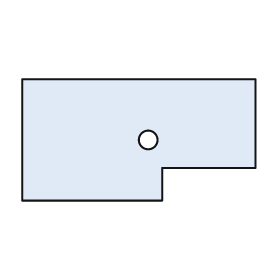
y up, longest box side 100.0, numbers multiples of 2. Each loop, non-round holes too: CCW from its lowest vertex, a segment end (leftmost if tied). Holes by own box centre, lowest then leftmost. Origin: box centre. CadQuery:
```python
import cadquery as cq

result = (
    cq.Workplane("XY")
    .moveTo(-50.0, -26.0)
    .lineTo(10.0, -26.0)
    .lineTo(10.0, -12.0)
    .lineTo(50.0, -12.0)
    .lineTo(50.0, 26.0)
    .lineTo(-50.0, 26.0)
    .close()
    .moveTo(4.0, 0.0)
    .circle(4.0)
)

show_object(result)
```